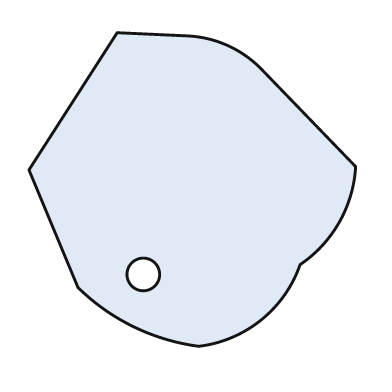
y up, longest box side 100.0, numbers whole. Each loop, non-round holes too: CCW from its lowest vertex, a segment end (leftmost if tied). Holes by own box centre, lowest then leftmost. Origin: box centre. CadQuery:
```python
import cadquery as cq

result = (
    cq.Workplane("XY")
    .moveTo(2.0, -48.0)
    .threePointArc((21.0, -40.0), (33.0, -23.0))
    .threePointArc((45.0, -10.0), (50.0, 7.0))
    .lineTo(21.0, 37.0)
    .threePointArc((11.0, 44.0), (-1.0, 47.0))
    .lineTo(-23.0, 48.0)
    .lineTo(-50.0, 6.0)
    .lineTo(-35.0, -30.0)
    .threePointArc((-18.0, -42.0), (2.0, -48.0))
    .close()
    .moveTo(-15.0, -26.0)
    .circle(5.0)
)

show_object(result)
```